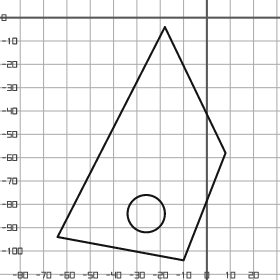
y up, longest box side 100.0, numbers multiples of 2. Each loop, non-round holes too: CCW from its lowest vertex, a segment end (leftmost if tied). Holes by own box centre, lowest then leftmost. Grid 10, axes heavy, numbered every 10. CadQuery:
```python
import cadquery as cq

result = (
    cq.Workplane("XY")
    .moveTo(-10.0, -104.0)
    .lineTo(8.0, -58.0)
    .lineTo(-18.0, -4.0)
    .lineTo(-64.0, -94.0)
    .close()
    .moveTo(-26.0, -84.0)
    .circle(8.0)
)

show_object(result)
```